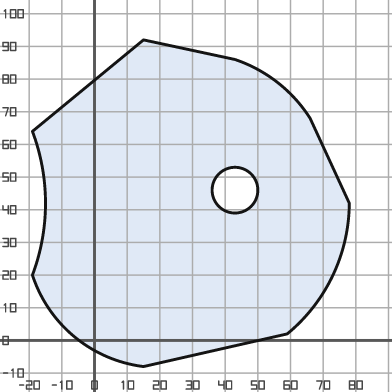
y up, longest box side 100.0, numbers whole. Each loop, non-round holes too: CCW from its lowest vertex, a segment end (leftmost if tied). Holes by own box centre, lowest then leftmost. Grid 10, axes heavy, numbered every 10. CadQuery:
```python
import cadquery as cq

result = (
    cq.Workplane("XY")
    .moveTo(15.0, -8.0)
    .lineTo(59.0, 2.0)
    .threePointArc((73.0, 20.0), (78.0, 42.0))
    .lineTo(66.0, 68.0)
    .threePointArc((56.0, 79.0), (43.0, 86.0))
    .lineTo(15.0, 92.0)
    .lineTo(-19.0, 64.0)
    .threePointArc((-15.0, 42.0), (-19.0, 20.0))
    .threePointArc((-6.0, 1.0), (15.0, -8.0))
    .close()
    .moveTo(43.0, 46.0)
    .circle(7.0)
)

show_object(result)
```